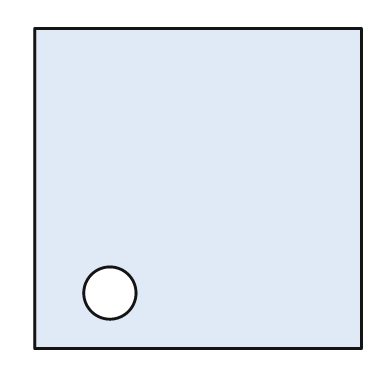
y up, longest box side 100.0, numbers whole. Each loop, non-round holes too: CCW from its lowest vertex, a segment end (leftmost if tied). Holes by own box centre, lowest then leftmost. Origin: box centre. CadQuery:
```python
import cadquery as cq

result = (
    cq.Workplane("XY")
    .moveTo(-50.0, -49.0)
    .lineTo(50.0, -49.0)
    .lineTo(50.0, 49.0)
    .lineTo(-50.0, 49.0)
    .close()
    .moveTo(-27.0, -32.0)
    .circle(8.0)
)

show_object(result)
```